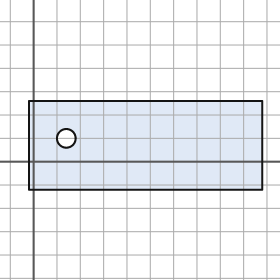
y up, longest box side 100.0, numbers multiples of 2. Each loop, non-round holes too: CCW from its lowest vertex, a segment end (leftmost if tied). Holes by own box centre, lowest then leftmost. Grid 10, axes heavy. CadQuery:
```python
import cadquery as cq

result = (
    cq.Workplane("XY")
    .moveTo(-2.0, -12.0)
    .lineTo(98.0, -12.0)
    .lineTo(98.0, 26.0)
    .lineTo(-2.0, 26.0)
    .close()
    .moveTo(14.0, 10.0)
    .circle(4.0)
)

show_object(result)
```